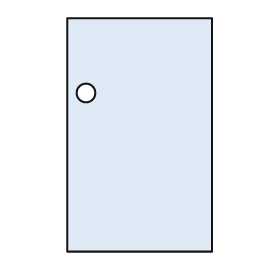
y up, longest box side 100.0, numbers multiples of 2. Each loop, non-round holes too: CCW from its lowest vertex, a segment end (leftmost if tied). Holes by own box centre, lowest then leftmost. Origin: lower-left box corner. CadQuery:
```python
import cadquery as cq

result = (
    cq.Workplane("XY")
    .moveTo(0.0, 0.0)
    .lineTo(62.0, 0.0)
    .lineTo(62.0, 100.0)
    .lineTo(0.0, 100.0)
    .close()
    .moveTo(8.0, 68.0)
    .circle(4.0)
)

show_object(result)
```